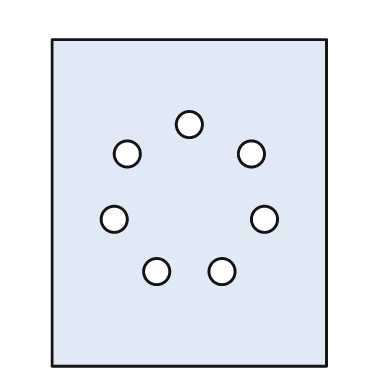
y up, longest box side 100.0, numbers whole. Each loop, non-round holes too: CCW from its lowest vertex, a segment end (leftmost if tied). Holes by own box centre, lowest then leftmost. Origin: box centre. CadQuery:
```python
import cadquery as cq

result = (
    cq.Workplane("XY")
    .moveTo(-42.0, -50.0)
    .lineTo(42.0, -50.0)
    .lineTo(42.0, 50.0)
    .lineTo(-42.0, 50.0)
    .close()
    .moveTo(-10.0, -21.0)
    .circle(4.0)
    .moveTo(10.0, -21.0)
    .circle(4.0)
    .moveTo(-23.0, -5.0)
    .circle(4.0)
    .moveTo(23.0, -5.0)
    .circle(4.0)
    .moveTo(-19.0, 15.0)
    .circle(4.0)
    .moveTo(19.0, 15.0)
    .circle(4.0)
    .moveTo(0.0, 24.0)
    .circle(4.0)
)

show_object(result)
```